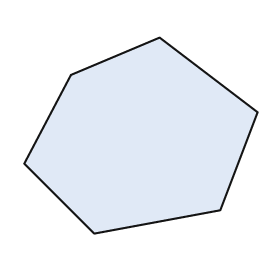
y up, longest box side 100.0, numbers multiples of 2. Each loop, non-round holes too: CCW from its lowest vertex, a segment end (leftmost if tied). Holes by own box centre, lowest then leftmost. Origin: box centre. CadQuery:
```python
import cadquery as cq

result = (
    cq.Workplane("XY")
    .moveTo(-20.0, -42.0)
    .lineTo(34.0, -32.0)
    .lineTo(50.0, 10.0)
    .lineTo(8.0, 42.0)
    .lineTo(-30.0, 26.0)
    .lineTo(-50.0, -12.0)
    .close()
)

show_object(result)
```